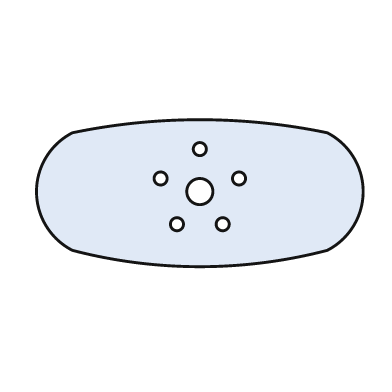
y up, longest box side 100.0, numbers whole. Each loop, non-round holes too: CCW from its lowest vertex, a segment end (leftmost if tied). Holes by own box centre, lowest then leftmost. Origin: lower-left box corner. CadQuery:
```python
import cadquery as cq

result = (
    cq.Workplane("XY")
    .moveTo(11.0, 5.0)
    .threePointArc((50.0, 0.0), (89.0, 5.0))
    .threePointArc((100.0, 23.0), (89.0, 41.0))
    .threePointArc((50.0, 45.0), (11.0, 41.0))
    .threePointArc((0.0, 23.0), (11.0, 5.0))
    .close()
    .moveTo(43.0, 13.0)
    .circle(2.0)
    .moveTo(57.0, 13.0)
    .circle(2.0)
    .moveTo(50.0, 23.0)
    .circle(4.0)
    .moveTo(38.0, 27.0)
    .circle(2.0)
    .moveTo(62.0, 27.0)
    .circle(2.0)
    .moveTo(50.0, 36.0)
    .circle(2.0)
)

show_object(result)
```